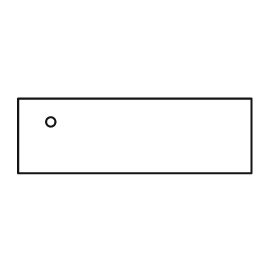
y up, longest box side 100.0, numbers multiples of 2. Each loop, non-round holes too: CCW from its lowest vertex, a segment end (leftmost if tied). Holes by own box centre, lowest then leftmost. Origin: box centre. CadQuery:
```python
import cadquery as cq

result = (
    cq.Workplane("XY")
    .moveTo(-50.0, -16.0)
    .lineTo(50.0, -16.0)
    .lineTo(50.0, 16.0)
    .lineTo(-50.0, 16.0)
    .close()
    .moveTo(-36.0, 6.0)
    .circle(2.0)
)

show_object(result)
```